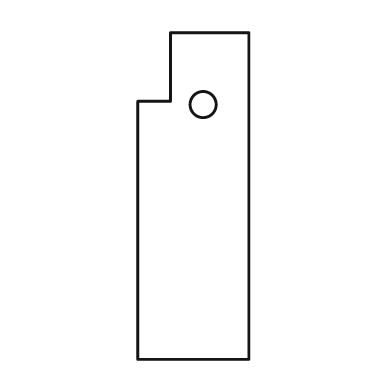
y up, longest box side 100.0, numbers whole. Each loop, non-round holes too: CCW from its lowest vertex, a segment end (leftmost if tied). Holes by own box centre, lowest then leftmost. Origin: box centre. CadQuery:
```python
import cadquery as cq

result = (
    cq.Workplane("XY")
    .moveTo(-17.0, -50.0)
    .lineTo(17.0, -50.0)
    .lineTo(17.0, 50.0)
    .lineTo(-7.0, 50.0)
    .lineTo(-7.0, 29.0)
    .lineTo(-17.0, 29.0)
    .close()
    .moveTo(3.0, 28.0)
    .circle(4.0)
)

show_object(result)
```